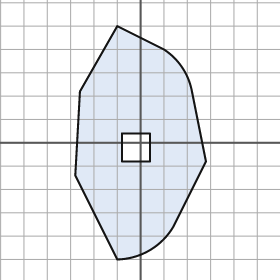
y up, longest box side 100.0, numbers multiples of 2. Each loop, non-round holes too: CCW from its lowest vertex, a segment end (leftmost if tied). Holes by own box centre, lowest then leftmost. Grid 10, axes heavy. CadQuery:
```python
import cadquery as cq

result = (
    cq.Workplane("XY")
    .moveTo(-10.0, -50.0)
    .threePointArc((4.0, -46.0), (14.0, -36.0))
    .lineTo(28.0, -8.0)
    .lineTo(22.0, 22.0)
    .threePointArc((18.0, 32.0), (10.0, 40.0))
    .lineTo(-10.0, 50.0)
    .lineTo(-26.0, 22.0)
    .lineTo(-28.0, -14.0)
    .close()
    .moveTo(-8.0, -8.0)
    .lineTo(4.0, -8.0)
    .lineTo(4.0, 4.0)
    .lineTo(-8.0, 4.0)
    .close()
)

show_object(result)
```